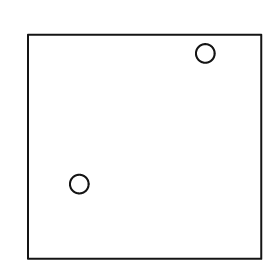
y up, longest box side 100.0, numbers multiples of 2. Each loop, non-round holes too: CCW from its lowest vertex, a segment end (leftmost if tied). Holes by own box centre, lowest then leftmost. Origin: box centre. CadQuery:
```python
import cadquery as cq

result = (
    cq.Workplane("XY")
    .moveTo(-50.0, -48.0)
    .lineTo(50.0, -48.0)
    .lineTo(50.0, 48.0)
    .lineTo(-50.0, 48.0)
    .close()
    .moveTo(-28.0, -16.0)
    .circle(4.0)
    .moveTo(26.0, 40.0)
    .circle(4.0)
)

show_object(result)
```